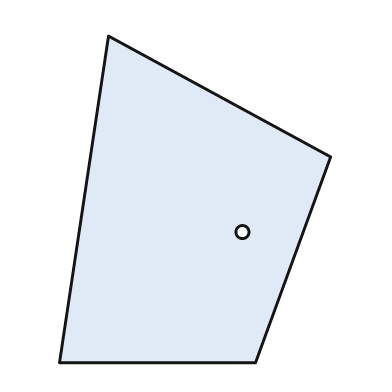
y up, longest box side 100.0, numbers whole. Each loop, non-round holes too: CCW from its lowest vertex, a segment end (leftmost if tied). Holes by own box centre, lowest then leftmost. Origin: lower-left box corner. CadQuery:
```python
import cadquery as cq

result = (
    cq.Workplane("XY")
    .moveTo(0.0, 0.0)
    .lineTo(60.0, 0.0)
    .lineTo(83.0, 63.0)
    .lineTo(15.0, 100.0)
    .close()
    .moveTo(56.0, 40.0)
    .circle(2.0)
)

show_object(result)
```